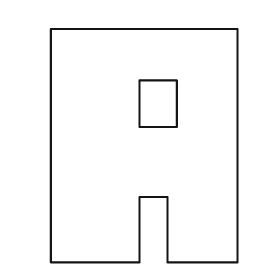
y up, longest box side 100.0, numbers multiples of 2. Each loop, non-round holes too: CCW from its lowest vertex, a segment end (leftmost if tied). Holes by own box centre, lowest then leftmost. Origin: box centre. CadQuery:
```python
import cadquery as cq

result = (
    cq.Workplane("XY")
    .moveTo(-40.0, -50.0)
    .lineTo(-2.0, -50.0)
    .lineTo(-2.0, -22.0)
    .lineTo(10.0, -22.0)
    .lineTo(10.0, -50.0)
    .lineTo(40.0, -50.0)
    .lineTo(40.0, 50.0)
    .lineTo(-40.0, 50.0)
    .close()
    .moveTo(-2.0, 8.0)
    .lineTo(14.0, 8.0)
    .lineTo(14.0, 28.0)
    .lineTo(-2.0, 28.0)
    .close()
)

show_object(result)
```